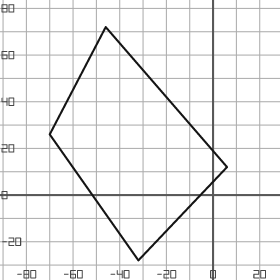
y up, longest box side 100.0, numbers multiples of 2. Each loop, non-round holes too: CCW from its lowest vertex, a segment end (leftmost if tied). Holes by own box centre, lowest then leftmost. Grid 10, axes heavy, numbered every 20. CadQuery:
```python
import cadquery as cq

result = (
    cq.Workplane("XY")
    .moveTo(-32.0, -28.0)
    .lineTo(6.0, 12.0)
    .lineTo(-46.0, 72.0)
    .lineTo(-70.0, 26.0)
    .close()
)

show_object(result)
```